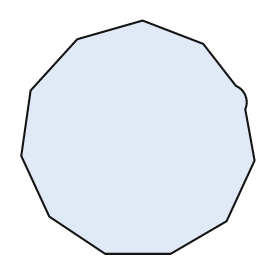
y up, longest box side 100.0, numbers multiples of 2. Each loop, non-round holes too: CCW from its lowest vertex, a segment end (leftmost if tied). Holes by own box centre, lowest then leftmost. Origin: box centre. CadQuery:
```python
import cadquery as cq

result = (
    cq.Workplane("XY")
    .moveTo(-14.0, -50.0)
    .lineTo(14.0, -50.0)
    .lineTo(38.0, -36.0)
    .lineTo(50.0, -10.0)
    .lineTo(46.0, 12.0)
    .threePointArc((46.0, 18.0), (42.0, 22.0))
    .lineTo(28.0, 40.0)
    .lineTo(2.0, 50.0)
    .lineTo(-26.0, 42.0)
    .lineTo(-46.0, 20.0)
    .lineTo(-50.0, -8.0)
    .lineTo(-38.0, -34.0)
    .close()
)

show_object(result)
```